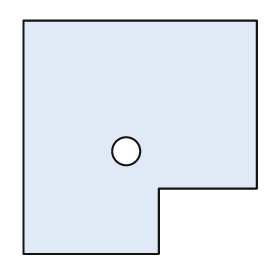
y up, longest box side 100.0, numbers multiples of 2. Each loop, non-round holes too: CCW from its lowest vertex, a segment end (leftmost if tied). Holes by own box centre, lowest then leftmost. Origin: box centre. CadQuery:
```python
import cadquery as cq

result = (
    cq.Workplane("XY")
    .moveTo(-50.0, -50.0)
    .lineTo(8.0, -50.0)
    .lineTo(8.0, -22.0)
    .lineTo(50.0, -22.0)
    .lineTo(50.0, 50.0)
    .lineTo(-50.0, 50.0)
    .close()
    .moveTo(-6.0, -6.0)
    .circle(6.0)
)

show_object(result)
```